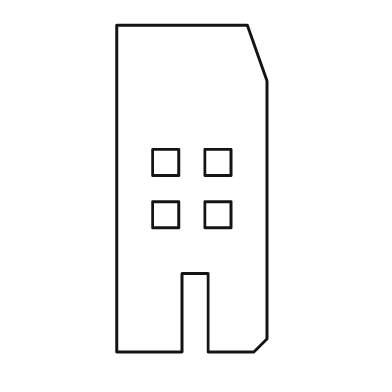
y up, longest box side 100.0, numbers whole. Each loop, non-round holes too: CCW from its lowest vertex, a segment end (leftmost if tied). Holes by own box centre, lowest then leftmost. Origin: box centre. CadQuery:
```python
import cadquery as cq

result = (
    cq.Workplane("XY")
    .moveTo(-23.0, -50.0)
    .lineTo(-3.0, -50.0)
    .lineTo(-3.0, -26.0)
    .lineTo(5.0, -26.0)
    .lineTo(5.0, -50.0)
    .lineTo(19.0, -50.0)
    .lineTo(23.0, -46.0)
    .lineTo(23.0, 33.0)
    .lineTo(17.0, 50.0)
    .lineTo(-23.0, 50.0)
    .close()
    .moveTo(-12.0, -12.0)
    .lineTo(-4.0, -12.0)
    .lineTo(-4.0, -4.0)
    .lineTo(-12.0, -4.0)
    .close()
    .moveTo(4.0, -12.0)
    .lineTo(12.0, -12.0)
    .lineTo(12.0, -4.0)
    .lineTo(4.0, -4.0)
    .close()
    .moveTo(-12.0, 4.0)
    .lineTo(-4.0, 4.0)
    .lineTo(-4.0, 12.0)
    .lineTo(-12.0, 12.0)
    .close()
    .moveTo(4.0, 4.0)
    .lineTo(12.0, 4.0)
    .lineTo(12.0, 12.0)
    .lineTo(4.0, 12.0)
    .close()
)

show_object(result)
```